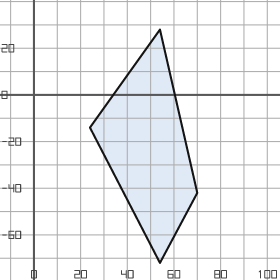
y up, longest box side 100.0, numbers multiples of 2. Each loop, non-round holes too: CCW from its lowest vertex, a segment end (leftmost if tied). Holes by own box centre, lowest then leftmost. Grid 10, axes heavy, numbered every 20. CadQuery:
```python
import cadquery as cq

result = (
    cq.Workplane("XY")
    .moveTo(54.0, -72.0)
    .lineTo(70.0, -42.0)
    .lineTo(54.0, 28.0)
    .lineTo(24.0, -14.0)
    .close()
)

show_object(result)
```